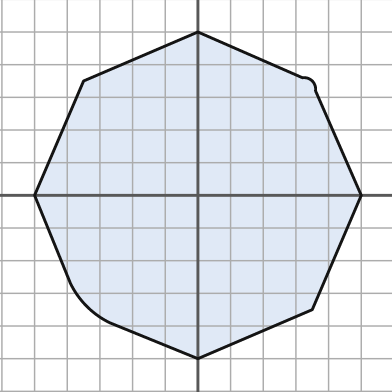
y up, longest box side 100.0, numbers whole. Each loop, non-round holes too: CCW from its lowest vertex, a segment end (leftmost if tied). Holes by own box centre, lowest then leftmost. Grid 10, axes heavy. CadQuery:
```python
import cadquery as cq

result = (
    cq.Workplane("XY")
    .moveTo(0.0, -50.0)
    .lineTo(35.0, -35.0)
    .lineTo(50.0, 0.0)
    .lineTo(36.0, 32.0)
    .threePointArc((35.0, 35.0), (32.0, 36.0))
    .lineTo(0.0, 50.0)
    .lineTo(-35.0, 35.0)
    .lineTo(-50.0, 0.0)
    .lineTo(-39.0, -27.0)
    .threePointArc((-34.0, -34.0), (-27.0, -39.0))
    .close()
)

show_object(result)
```